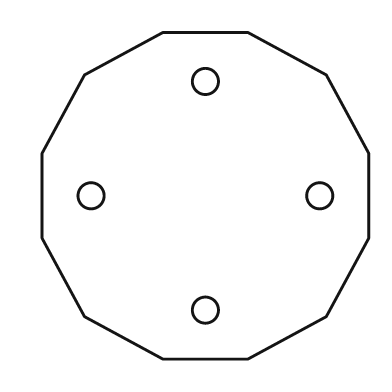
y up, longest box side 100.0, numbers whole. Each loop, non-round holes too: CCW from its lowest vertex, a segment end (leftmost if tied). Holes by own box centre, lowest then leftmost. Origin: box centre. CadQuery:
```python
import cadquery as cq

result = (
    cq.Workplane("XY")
    .moveTo(-13.0, -50.0)
    .lineTo(13.0, -50.0)
    .lineTo(37.0, -37.0)
    .lineTo(50.0, -13.0)
    .lineTo(50.0, 13.0)
    .lineTo(37.0, 37.0)
    .lineTo(13.0, 50.0)
    .lineTo(-13.0, 50.0)
    .lineTo(-37.0, 37.0)
    .lineTo(-50.0, 13.0)
    .lineTo(-50.0, -13.0)
    .lineTo(-37.0, -37.0)
    .close()
    .moveTo(0.0, -35.0)
    .circle(4.0)
    .moveTo(-35.0, 0.0)
    .circle(4.0)
    .moveTo(35.0, 0.0)
    .circle(4.0)
    .moveTo(0.0, 35.0)
    .circle(4.0)
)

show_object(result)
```